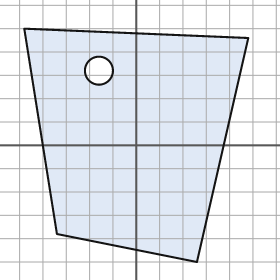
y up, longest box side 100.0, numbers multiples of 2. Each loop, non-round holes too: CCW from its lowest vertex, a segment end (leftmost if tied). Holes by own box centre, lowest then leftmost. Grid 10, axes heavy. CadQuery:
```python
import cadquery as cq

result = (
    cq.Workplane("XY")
    .moveTo(26.0, -50.0)
    .lineTo(48.0, 46.0)
    .lineTo(-48.0, 50.0)
    .lineTo(-34.0, -38.0)
    .close()
    .moveTo(-16.0, 32.0)
    .circle(6.0)
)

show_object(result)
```